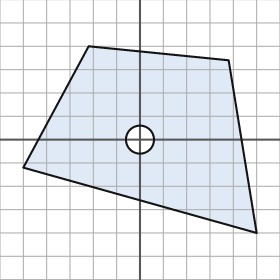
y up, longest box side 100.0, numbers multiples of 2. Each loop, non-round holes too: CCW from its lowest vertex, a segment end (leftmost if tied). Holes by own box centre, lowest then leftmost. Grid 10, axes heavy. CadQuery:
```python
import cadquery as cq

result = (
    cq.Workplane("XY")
    .moveTo(50.0, -40.0)
    .lineTo(38.0, 34.0)
    .lineTo(-22.0, 40.0)
    .lineTo(-50.0, -12.0)
    .close()
    .moveTo(0.0, 0.0)
    .circle(6.0)
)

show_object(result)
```